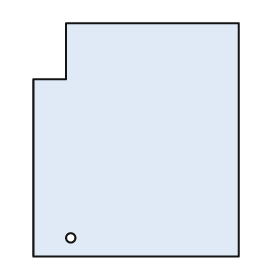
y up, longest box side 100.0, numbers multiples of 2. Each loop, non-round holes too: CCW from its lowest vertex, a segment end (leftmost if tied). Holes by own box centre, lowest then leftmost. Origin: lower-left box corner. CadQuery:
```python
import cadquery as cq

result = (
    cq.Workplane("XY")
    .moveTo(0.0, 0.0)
    .lineTo(88.0, 0.0)
    .lineTo(88.0, 100.0)
    .lineTo(14.0, 100.0)
    .lineTo(14.0, 76.0)
    .lineTo(0.0, 76.0)
    .close()
    .moveTo(16.0, 8.0)
    .circle(2.0)
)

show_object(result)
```